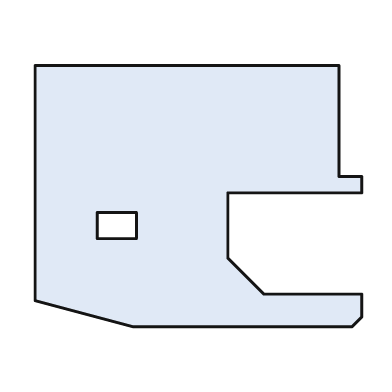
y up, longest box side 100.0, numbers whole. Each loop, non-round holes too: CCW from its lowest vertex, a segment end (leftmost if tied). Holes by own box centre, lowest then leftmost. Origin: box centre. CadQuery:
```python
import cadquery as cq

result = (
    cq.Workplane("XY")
    .moveTo(-20.0, -40.0)
    .lineTo(47.0, -40.0)
    .lineTo(50.0, -37.0)
    .lineTo(50.0, -30.0)
    .lineTo(20.0, -30.0)
    .lineTo(9.0, -19.0)
    .lineTo(9.0, 1.0)
    .lineTo(50.0, 1.0)
    .lineTo(50.0, 6.0)
    .lineTo(43.0, 6.0)
    .lineTo(43.0, 40.0)
    .lineTo(-50.0, 40.0)
    .lineTo(-50.0, -32.0)
    .close()
    .moveTo(-31.0, -13.0)
    .lineTo(-19.0, -13.0)
    .lineTo(-19.0, -5.0)
    .lineTo(-31.0, -5.0)
    .close()
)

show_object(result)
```